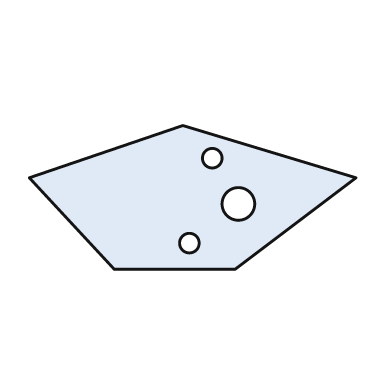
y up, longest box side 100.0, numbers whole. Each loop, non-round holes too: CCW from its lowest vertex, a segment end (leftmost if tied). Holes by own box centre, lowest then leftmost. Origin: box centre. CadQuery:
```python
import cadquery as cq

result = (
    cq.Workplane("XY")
    .moveTo(-24.0, -22.0)
    .lineTo(13.0, -22.0)
    .lineTo(50.0, 6.0)
    .lineTo(-3.0, 22.0)
    .lineTo(-50.0, 6.0)
    .close()
    .moveTo(-1.0, -14.0)
    .circle(3.0)
    .moveTo(14.0, -2.0)
    .circle(5.0)
    .moveTo(6.0, 12.0)
    .circle(3.0)
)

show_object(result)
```